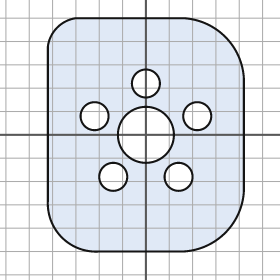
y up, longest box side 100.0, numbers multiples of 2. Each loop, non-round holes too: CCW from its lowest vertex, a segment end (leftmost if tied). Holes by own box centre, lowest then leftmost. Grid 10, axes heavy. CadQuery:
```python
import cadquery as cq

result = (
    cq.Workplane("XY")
    .moveTo(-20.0, -50.0)
    .lineTo(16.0, -50.0)
    .threePointArc((34.0, -42.0), (42.0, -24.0))
    .lineTo(42.0, 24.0)
    .threePointArc((34.0, 42.0), (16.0, 50.0))
    .lineTo(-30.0, 50.0)
    .threePointArc((-38.0, 46.0), (-42.0, 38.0))
    .lineTo(-42.0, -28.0)
    .threePointArc((-36.0, -44.0), (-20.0, -50.0))
    .close()
    .moveTo(-14.0, -18.0)
    .circle(6.0)
    .moveTo(14.0, -18.0)
    .circle(6.0)
    .moveTo(0.0, 0.0)
    .circle(12.0)
    .moveTo(-22.0, 8.0)
    .circle(6.0)
    .moveTo(22.0, 8.0)
    .circle(6.0)
    .moveTo(0.0, 22.0)
    .circle(6.0)
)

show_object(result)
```